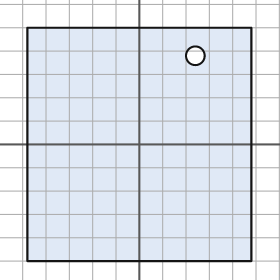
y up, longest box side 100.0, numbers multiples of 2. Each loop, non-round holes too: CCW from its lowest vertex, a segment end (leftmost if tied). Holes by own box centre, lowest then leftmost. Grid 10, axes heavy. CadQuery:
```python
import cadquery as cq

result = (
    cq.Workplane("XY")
    .moveTo(-48.0, -50.0)
    .lineTo(48.0, -50.0)
    .lineTo(48.0, 50.0)
    .lineTo(-48.0, 50.0)
    .close()
    .moveTo(24.0, 38.0)
    .circle(4.0)
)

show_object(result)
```